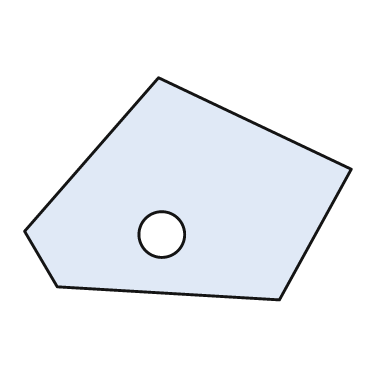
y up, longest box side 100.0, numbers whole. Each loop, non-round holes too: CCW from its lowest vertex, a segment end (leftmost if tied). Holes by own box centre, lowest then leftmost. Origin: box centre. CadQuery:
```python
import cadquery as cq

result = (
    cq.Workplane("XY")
    .moveTo(28.0, -34.0)
    .lineTo(50.0, 6.0)
    .lineTo(-9.0, 34.0)
    .lineTo(-50.0, -13.0)
    .lineTo(-40.0, -30.0)
    .close()
    .moveTo(-8.0, -14.0)
    .circle(7.0)
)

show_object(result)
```